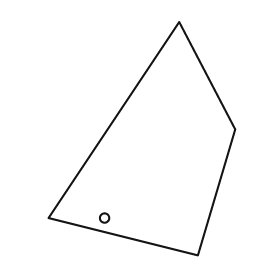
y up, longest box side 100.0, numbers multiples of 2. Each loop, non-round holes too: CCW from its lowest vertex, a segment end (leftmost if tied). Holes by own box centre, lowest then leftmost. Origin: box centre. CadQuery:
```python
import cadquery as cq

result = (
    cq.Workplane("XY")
    .moveTo(24.0, -50.0)
    .lineTo(40.0, 4.0)
    .lineTo(16.0, 50.0)
    .lineTo(-40.0, -34.0)
    .close()
    .moveTo(-16.0, -34.0)
    .circle(2.0)
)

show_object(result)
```